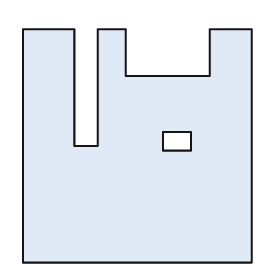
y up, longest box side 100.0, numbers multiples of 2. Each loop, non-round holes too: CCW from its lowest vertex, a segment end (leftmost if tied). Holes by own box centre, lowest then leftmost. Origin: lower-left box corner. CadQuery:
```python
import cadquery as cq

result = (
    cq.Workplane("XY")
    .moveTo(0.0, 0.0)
    .lineTo(98.0, 0.0)
    .lineTo(98.0, 100.0)
    .lineTo(80.0, 100.0)
    .lineTo(80.0, 80.0)
    .lineTo(44.0, 80.0)
    .lineTo(44.0, 100.0)
    .lineTo(32.0, 100.0)
    .lineTo(32.0, 50.0)
    .lineTo(22.0, 50.0)
    .lineTo(22.0, 100.0)
    .lineTo(0.0, 100.0)
    .close()
    .moveTo(60.0, 48.0)
    .lineTo(72.0, 48.0)
    .lineTo(72.0, 56.0)
    .lineTo(60.0, 56.0)
    .close()
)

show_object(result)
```